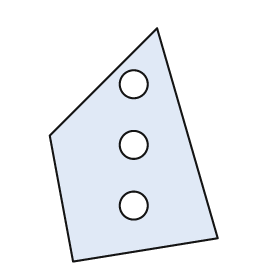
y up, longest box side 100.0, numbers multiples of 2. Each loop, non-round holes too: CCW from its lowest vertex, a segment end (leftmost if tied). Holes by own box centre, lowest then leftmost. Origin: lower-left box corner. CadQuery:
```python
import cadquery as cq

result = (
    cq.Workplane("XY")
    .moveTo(10.0, 0.0)
    .lineTo(72.0, 10.0)
    .lineTo(46.0, 100.0)
    .lineTo(0.0, 54.0)
    .close()
    .moveTo(36.0, 24.0)
    .circle(6.0)
    .moveTo(36.0, 50.0)
    .circle(6.0)
    .moveTo(36.0, 76.0)
    .circle(6.0)
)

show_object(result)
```